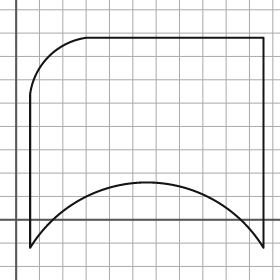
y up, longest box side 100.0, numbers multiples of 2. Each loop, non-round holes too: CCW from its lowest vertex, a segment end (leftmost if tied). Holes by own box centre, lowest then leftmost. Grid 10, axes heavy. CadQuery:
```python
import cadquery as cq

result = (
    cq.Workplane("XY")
    .moveTo(6.0, -12.0)
    .threePointArc((56.0, 16.0), (106.0, -12.0))
    .lineTo(106.0, 78.0)
    .lineTo(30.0, 78.0)
    .threePointArc((14.0, 70.0), (6.0, 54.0))
    .close()
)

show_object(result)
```